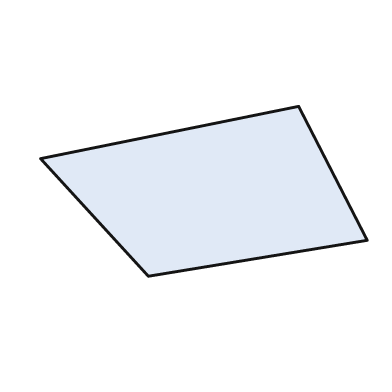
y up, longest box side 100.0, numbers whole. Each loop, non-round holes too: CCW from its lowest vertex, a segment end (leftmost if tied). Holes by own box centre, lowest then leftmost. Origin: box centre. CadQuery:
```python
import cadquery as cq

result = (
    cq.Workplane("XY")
    .moveTo(-17.0, -26.0)
    .lineTo(50.0, -15.0)
    .lineTo(29.0, 26.0)
    .lineTo(-50.0, 10.0)
    .close()
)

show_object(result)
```